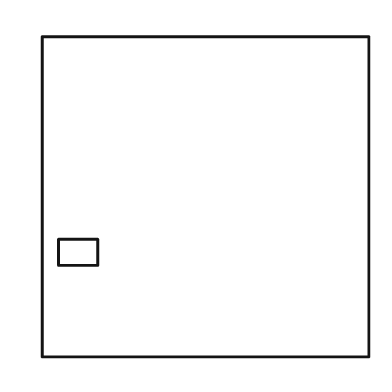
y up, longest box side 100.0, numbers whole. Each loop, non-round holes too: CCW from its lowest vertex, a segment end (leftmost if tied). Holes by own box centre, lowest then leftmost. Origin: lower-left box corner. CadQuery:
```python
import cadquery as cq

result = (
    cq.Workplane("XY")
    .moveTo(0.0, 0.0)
    .lineTo(100.0, 0.0)
    .lineTo(100.0, 98.0)
    .lineTo(0.0, 98.0)
    .close()
    .moveTo(5.0, 28.0)
    .lineTo(17.0, 28.0)
    .lineTo(17.0, 36.0)
    .lineTo(5.0, 36.0)
    .close()
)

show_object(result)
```